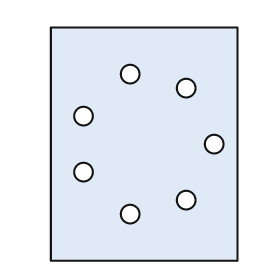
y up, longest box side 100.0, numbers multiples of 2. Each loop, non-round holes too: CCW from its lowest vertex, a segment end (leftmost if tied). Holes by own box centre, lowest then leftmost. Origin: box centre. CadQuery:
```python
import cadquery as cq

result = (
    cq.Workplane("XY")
    .moveTo(-40.0, -50.0)
    .lineTo(40.0, -50.0)
    .lineTo(40.0, 50.0)
    .lineTo(-40.0, 50.0)
    .close()
    .moveTo(-6.0, -30.0)
    .circle(4.0)
    .moveTo(18.0, -24.0)
    .circle(4.0)
    .moveTo(-26.0, -12.0)
    .circle(4.0)
    .moveTo(30.0, 0.0)
    .circle(4.0)
    .moveTo(-26.0, 12.0)
    .circle(4.0)
    .moveTo(18.0, 24.0)
    .circle(4.0)
    .moveTo(-6.0, 30.0)
    .circle(4.0)
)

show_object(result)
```